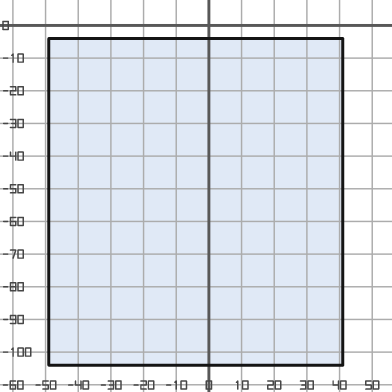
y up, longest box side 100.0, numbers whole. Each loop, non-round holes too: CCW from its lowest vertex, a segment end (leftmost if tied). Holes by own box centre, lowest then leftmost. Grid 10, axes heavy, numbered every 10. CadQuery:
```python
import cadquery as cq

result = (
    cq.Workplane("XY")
    .moveTo(-49.0, -104.0)
    .lineTo(41.0, -104.0)
    .lineTo(41.0, -4.0)
    .lineTo(-49.0, -4.0)
    .close()
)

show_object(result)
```